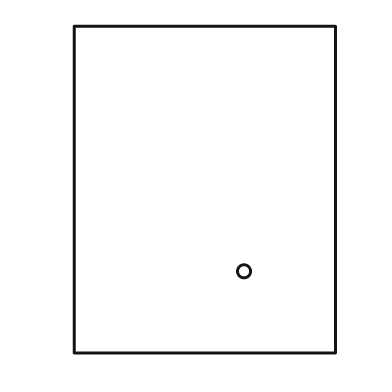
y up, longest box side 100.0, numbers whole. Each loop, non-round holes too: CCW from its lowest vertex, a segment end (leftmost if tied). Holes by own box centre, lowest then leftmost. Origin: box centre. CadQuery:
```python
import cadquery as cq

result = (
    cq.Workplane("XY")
    .moveTo(-40.0, -50.0)
    .lineTo(40.0, -50.0)
    .lineTo(40.0, 50.0)
    .lineTo(-40.0, 50.0)
    .close()
    .moveTo(12.0, -25.0)
    .circle(2.0)
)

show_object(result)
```